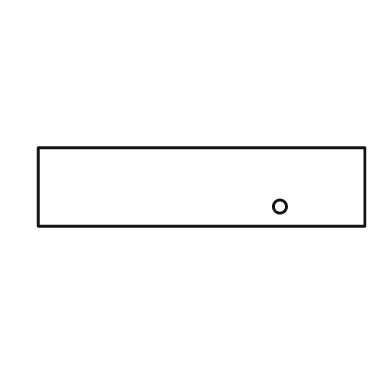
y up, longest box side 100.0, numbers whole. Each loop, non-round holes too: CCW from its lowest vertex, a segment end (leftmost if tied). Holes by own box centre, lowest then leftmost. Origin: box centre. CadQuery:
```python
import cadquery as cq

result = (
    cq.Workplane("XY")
    .moveTo(-50.0, -12.0)
    .lineTo(50.0, -12.0)
    .lineTo(50.0, 12.0)
    .lineTo(-50.0, 12.0)
    .close()
    .moveTo(24.0, -6.0)
    .circle(2.0)
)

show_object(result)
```